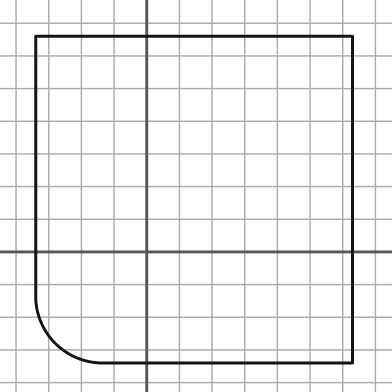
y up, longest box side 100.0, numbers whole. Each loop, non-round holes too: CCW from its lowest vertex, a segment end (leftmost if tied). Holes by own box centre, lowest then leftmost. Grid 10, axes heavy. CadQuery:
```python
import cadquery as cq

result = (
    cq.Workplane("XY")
    .moveTo(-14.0, -34.0)
    .lineTo(63.0, -34.0)
    .lineTo(63.0, 66.0)
    .lineTo(-34.0, 66.0)
    .lineTo(-34.0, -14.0)
    .threePointArc((-28.0, -28.0), (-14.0, -34.0))
    .close()
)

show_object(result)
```